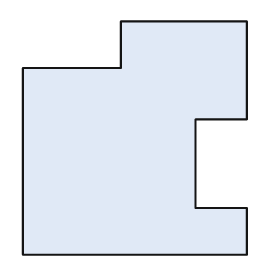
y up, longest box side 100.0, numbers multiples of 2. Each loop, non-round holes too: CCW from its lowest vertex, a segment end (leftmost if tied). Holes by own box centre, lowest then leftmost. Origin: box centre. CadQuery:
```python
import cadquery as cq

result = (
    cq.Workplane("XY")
    .moveTo(-48.0, -50.0)
    .lineTo(48.0, -50.0)
    .lineTo(48.0, -30.0)
    .lineTo(26.0, -30.0)
    .lineTo(26.0, 8.0)
    .lineTo(48.0, 8.0)
    .lineTo(48.0, 50.0)
    .lineTo(-6.0, 50.0)
    .lineTo(-6.0, 30.0)
    .lineTo(-48.0, 30.0)
    .close()
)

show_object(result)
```